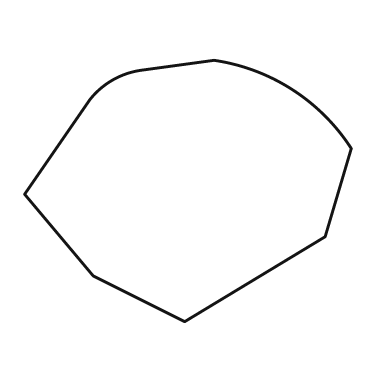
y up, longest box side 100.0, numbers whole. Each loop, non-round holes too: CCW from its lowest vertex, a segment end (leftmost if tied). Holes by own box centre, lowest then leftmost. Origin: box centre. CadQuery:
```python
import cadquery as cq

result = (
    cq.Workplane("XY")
    .moveTo(-1.0, -40.0)
    .lineTo(42.0, -14.0)
    .lineTo(50.0, 13.0)
    .threePointArc((32.0, 31.0), (8.0, 40.0))
    .lineTo(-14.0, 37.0)
    .threePointArc((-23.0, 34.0), (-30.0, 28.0))
    .lineTo(-50.0, -1.0)
    .lineTo(-29.0, -26.0)
    .close()
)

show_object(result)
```